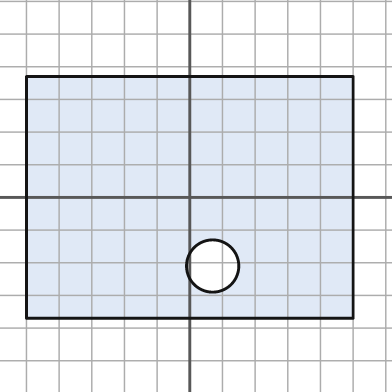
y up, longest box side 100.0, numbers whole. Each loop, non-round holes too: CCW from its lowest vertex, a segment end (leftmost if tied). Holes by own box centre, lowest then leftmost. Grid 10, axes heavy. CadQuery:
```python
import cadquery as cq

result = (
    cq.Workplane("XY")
    .moveTo(-50.0, -37.0)
    .lineTo(50.0, -37.0)
    .lineTo(50.0, 37.0)
    .lineTo(-50.0, 37.0)
    .close()
    .moveTo(7.0, -21.0)
    .circle(8.0)
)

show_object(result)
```